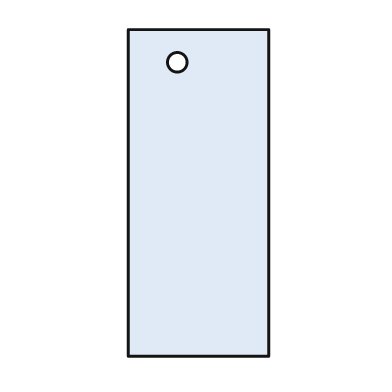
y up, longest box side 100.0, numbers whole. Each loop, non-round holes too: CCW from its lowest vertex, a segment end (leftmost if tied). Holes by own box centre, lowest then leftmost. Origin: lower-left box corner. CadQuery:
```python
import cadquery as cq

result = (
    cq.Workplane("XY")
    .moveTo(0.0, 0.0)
    .lineTo(43.0, 0.0)
    .lineTo(43.0, 100.0)
    .lineTo(0.0, 100.0)
    .close()
    .moveTo(15.0, 90.0)
    .circle(3.0)
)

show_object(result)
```